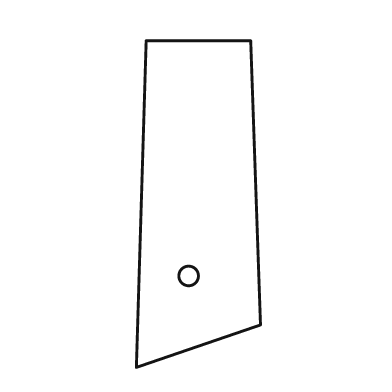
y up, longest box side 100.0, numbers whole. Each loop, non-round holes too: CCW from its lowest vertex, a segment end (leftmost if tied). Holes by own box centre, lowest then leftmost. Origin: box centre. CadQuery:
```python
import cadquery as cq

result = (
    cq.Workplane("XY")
    .moveTo(-19.0, -50.0)
    .lineTo(19.0, -37.0)
    .lineTo(16.0, 50.0)
    .lineTo(-16.0, 50.0)
    .close()
    .moveTo(-3.0, -22.0)
    .circle(3.0)
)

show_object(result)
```